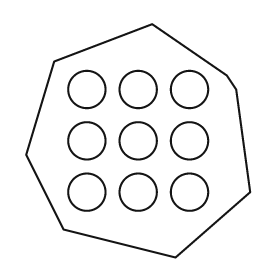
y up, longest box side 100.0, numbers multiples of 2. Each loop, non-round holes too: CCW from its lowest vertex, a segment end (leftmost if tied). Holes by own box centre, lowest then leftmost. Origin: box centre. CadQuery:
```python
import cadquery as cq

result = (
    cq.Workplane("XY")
    .moveTo(16.0, -50.0)
    .lineTo(48.0, -22.0)
    .lineTo(42.0, 22.0)
    .lineTo(38.0, 28.0)
    .lineTo(6.0, 50.0)
    .lineTo(-36.0, 34.0)
    .lineTo(-48.0, -6.0)
    .lineTo(-32.0, -38.0)
    .close()
    .moveTo(-22.0, -22.0)
    .circle(8.0)
    .moveTo(0.0, -22.0)
    .circle(8.0)
    .moveTo(22.0, -22.0)
    .circle(8.0)
    .moveTo(-22.0, 0.0)
    .circle(8.0)
    .moveTo(0.0, 0.0)
    .circle(8.0)
    .moveTo(22.0, 0.0)
    .circle(8.0)
    .moveTo(-22.0, 22.0)
    .circle(8.0)
    .moveTo(0.0, 22.0)
    .circle(8.0)
    .moveTo(22.0, 22.0)
    .circle(8.0)
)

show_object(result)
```